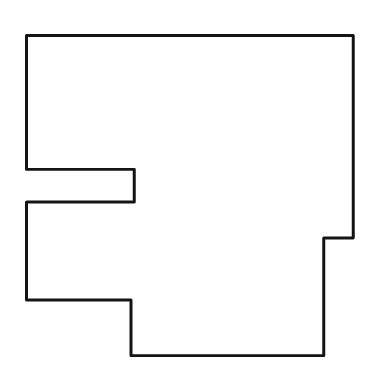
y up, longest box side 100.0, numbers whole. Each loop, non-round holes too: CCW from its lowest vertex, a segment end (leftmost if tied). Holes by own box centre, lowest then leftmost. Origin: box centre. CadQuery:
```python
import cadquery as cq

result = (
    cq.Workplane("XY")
    .moveTo(-18.0, -49.0)
    .lineTo(41.0, -49.0)
    .lineTo(41.0, -13.0)
    .lineTo(50.0, -13.0)
    .lineTo(50.0, 49.0)
    .lineTo(-50.0, 49.0)
    .lineTo(-50.0, 8.0)
    .lineTo(-17.0, 8.0)
    .lineTo(-17.0, -2.0)
    .lineTo(-50.0, -2.0)
    .lineTo(-50.0, -32.0)
    .lineTo(-18.0, -32.0)
    .close()
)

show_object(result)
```